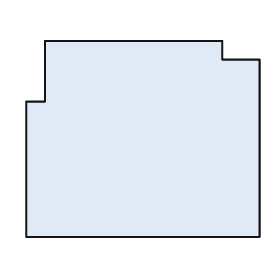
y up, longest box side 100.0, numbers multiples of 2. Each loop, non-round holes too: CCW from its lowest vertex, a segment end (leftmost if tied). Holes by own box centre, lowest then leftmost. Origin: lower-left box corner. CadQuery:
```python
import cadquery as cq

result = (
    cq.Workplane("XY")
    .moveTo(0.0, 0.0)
    .lineTo(100.0, 0.0)
    .lineTo(100.0, 76.0)
    .lineTo(84.0, 76.0)
    .lineTo(84.0, 84.0)
    .lineTo(8.0, 84.0)
    .lineTo(8.0, 58.0)
    .lineTo(0.0, 58.0)
    .close()
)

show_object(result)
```